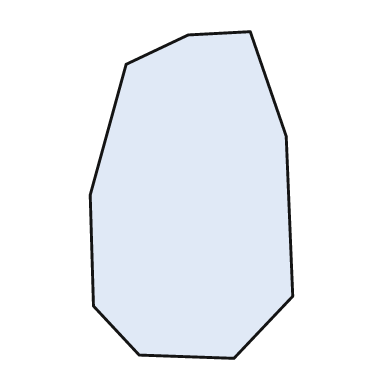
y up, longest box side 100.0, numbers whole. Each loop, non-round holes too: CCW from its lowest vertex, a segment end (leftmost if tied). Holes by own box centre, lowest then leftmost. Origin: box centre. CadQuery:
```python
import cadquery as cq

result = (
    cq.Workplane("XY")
    .moveTo(13.0, -50.0)
    .lineTo(31.0, -31.0)
    .lineTo(29.0, 18.0)
    .lineTo(18.0, 50.0)
    .lineTo(-1.0, 49.0)
    .lineTo(-20.0, 40.0)
    .lineTo(-31.0, 0.0)
    .lineTo(-30.0, -34.0)
    .lineTo(-16.0, -49.0)
    .close()
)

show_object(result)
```